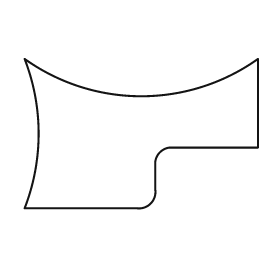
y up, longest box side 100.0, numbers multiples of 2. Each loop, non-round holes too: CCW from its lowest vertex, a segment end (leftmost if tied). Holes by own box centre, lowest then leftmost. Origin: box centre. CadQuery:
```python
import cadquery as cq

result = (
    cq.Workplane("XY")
    .moveTo(-50.0, -32.0)
    .lineTo(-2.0, -32.0)
    .threePointArc((4.0, -30.0), (6.0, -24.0))
    .lineTo(6.0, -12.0)
    .threePointArc((8.0, -8.0), (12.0, -6.0))
    .lineTo(50.0, -6.0)
    .lineTo(50.0, 32.0)
    .threePointArc((0.0, 16.0), (-50.0, 32.0))
    .threePointArc((-44.0, 0.0), (-50.0, -32.0))
    .close()
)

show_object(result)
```